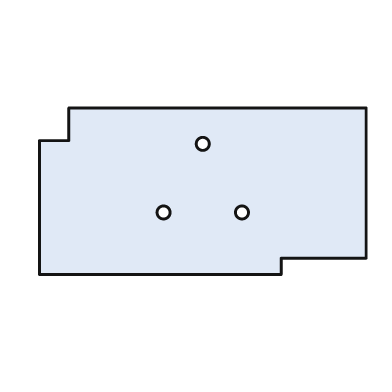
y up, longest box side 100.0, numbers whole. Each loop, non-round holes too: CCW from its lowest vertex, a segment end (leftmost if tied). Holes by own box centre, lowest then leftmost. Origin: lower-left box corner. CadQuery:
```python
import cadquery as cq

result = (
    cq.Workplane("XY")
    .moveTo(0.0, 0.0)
    .lineTo(74.0, 0.0)
    .lineTo(74.0, 5.0)
    .lineTo(100.0, 5.0)
    .lineTo(100.0, 51.0)
    .lineTo(9.0, 51.0)
    .lineTo(9.0, 41.0)
    .lineTo(0.0, 41.0)
    .close()
    .moveTo(38.0, 19.0)
    .circle(2.0)
    .moveTo(62.0, 19.0)
    .circle(2.0)
    .moveTo(50.0, 40.0)
    .circle(2.0)
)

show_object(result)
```